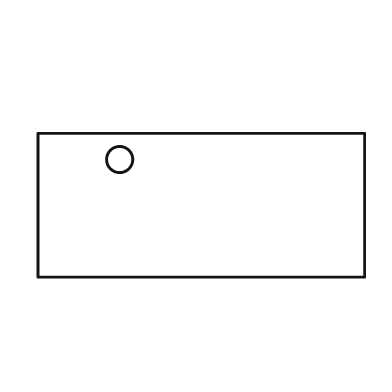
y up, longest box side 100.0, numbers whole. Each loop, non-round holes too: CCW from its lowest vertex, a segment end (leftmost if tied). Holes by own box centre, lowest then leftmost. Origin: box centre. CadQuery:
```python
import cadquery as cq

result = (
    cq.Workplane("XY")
    .moveTo(-50.0, -22.0)
    .lineTo(50.0, -22.0)
    .lineTo(50.0, 22.0)
    .lineTo(-50.0, 22.0)
    .close()
    .moveTo(-25.0, 14.0)
    .circle(4.0)
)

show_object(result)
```